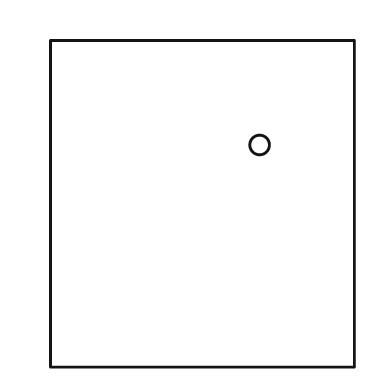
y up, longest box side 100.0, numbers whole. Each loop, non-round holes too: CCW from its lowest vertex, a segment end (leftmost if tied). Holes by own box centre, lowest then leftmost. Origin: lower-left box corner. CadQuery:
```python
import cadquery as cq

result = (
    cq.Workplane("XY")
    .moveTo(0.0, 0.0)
    .lineTo(93.0, 0.0)
    .lineTo(93.0, 100.0)
    .lineTo(0.0, 100.0)
    .close()
    .moveTo(64.0, 68.0)
    .circle(3.0)
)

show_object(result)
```